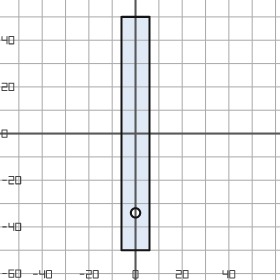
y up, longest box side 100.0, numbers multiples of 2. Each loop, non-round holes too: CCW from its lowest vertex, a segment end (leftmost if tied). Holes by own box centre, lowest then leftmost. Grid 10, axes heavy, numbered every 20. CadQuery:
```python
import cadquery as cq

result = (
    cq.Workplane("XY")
    .moveTo(-6.0, -50.0)
    .lineTo(6.0, -50.0)
    .lineTo(6.0, 50.0)
    .lineTo(-6.0, 50.0)
    .close()
    .moveTo(0.0, -34.0)
    .circle(2.0)
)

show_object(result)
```